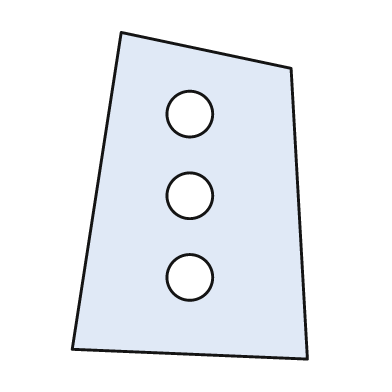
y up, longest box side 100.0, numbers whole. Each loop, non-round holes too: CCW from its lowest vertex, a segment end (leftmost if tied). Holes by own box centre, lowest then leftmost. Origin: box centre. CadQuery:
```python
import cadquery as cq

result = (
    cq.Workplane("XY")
    .moveTo(36.0, -50.0)
    .lineTo(31.0, 39.0)
    .lineTo(-21.0, 50.0)
    .lineTo(-36.0, -47.0)
    .close()
    .moveTo(0.0, -25.0)
    .circle(7.0)
    .moveTo(0.0, 0.0)
    .circle(7.0)
    .moveTo(0.0, 25.0)
    .circle(7.0)
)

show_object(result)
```